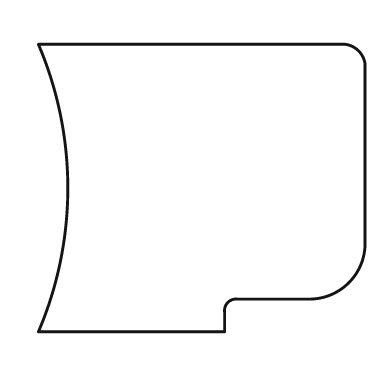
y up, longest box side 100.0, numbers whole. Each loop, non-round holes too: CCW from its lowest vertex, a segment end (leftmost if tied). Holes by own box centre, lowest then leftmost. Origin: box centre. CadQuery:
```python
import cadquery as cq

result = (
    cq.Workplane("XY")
    .moveTo(-50.0, -44.0)
    .lineTo(7.0, -44.0)
    .lineTo(7.0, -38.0)
    .threePointArc((8.0, -35.0), (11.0, -34.0))
    .lineTo(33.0, -34.0)
    .threePointArc((45.0, -29.0), (50.0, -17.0))
    .lineTo(50.0, 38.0)
    .threePointArc((48.0, 42.0), (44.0, 44.0))
    .lineTo(-50.0, 44.0)
    .threePointArc((-41.0, 0.0), (-50.0, -44.0))
    .close()
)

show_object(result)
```